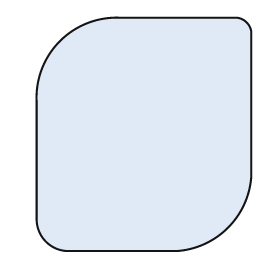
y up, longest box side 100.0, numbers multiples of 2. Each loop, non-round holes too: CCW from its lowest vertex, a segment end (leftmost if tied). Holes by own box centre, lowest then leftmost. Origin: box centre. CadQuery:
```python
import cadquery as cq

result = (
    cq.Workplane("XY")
    .moveTo(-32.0, -50.0)
    .lineTo(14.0, -50.0)
    .threePointArc((36.0, -40.0), (46.0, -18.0))
    .lineTo(46.0, 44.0)
    .threePointArc((44.0, 48.0), (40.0, 50.0))
    .lineTo(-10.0, 50.0)
    .threePointArc((-36.0, 40.0), (-46.0, 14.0))
    .lineTo(-46.0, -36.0)
    .threePointArc((-42.0, -46.0), (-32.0, -50.0))
    .close()
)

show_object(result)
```